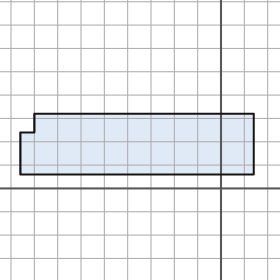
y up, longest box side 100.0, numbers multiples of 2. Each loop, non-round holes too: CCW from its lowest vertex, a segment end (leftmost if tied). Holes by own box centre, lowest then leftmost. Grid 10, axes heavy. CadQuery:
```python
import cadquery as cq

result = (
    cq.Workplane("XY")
    .moveTo(-86.0, 6.0)
    .lineTo(14.0, 6.0)
    .lineTo(14.0, 32.0)
    .lineTo(-80.0, 32.0)
    .lineTo(-80.0, 24.0)
    .lineTo(-86.0, 24.0)
    .close()
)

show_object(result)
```